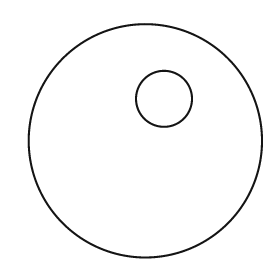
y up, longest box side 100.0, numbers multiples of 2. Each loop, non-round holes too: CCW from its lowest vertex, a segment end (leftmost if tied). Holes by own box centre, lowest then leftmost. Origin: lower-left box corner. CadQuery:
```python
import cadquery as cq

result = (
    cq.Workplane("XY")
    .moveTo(50.0, 50.0)
    .circle(50.0)
    .moveTo(58.0, 68.0)
    .circle(12.0)
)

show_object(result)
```